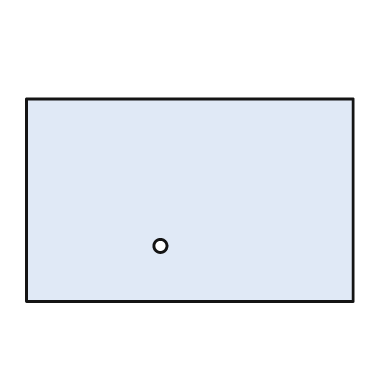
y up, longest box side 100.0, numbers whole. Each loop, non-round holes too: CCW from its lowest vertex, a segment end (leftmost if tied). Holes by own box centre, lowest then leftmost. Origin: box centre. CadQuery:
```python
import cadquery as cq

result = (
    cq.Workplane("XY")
    .moveTo(-50.0, -31.0)
    .lineTo(50.0, -31.0)
    .lineTo(50.0, 31.0)
    .lineTo(-50.0, 31.0)
    .close()
    .moveTo(-9.0, -14.0)
    .circle(2.0)
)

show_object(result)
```